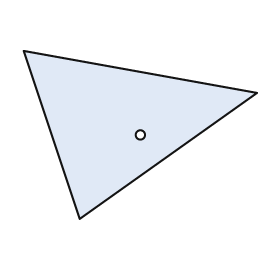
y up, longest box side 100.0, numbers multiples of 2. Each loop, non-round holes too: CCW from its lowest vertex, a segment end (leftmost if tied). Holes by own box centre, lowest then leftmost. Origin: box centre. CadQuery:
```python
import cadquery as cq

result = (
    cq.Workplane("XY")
    .moveTo(-26.0, -36.0)
    .lineTo(50.0, 18.0)
    .lineTo(-50.0, 36.0)
    .close()
    .moveTo(0.0, 0.0)
    .circle(2.0)
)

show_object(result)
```